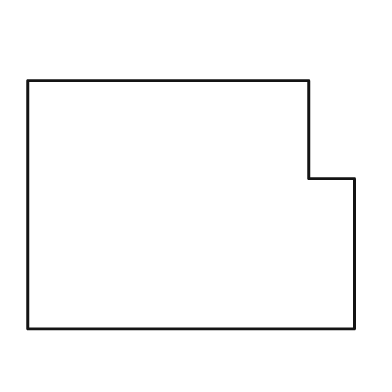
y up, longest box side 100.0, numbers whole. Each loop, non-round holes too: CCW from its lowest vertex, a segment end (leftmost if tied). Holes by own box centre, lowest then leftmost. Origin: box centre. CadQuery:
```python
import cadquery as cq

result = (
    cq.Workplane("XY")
    .moveTo(-50.0, -38.0)
    .lineTo(50.0, -38.0)
    .lineTo(50.0, 8.0)
    .lineTo(36.0, 8.0)
    .lineTo(36.0, 38.0)
    .lineTo(-50.0, 38.0)
    .close()
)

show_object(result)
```